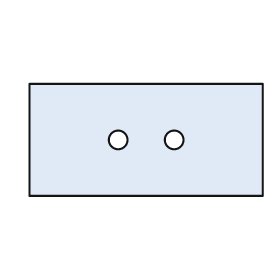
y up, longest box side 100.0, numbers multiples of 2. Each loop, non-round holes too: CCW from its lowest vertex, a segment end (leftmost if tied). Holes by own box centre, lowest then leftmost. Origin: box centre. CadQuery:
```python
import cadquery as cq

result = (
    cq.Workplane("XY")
    .moveTo(-50.0, -24.0)
    .lineTo(50.0, -24.0)
    .lineTo(50.0, 24.0)
    .lineTo(-50.0, 24.0)
    .close()
    .moveTo(-12.0, 0.0)
    .circle(4.0)
    .moveTo(12.0, 0.0)
    .circle(4.0)
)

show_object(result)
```